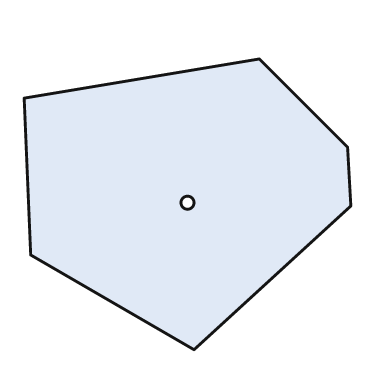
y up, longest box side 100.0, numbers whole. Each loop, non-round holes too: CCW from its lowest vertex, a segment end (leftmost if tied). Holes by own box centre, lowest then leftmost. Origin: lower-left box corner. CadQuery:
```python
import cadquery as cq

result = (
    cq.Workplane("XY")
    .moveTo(52.0, 0.0)
    .lineTo(100.0, 44.0)
    .lineTo(99.0, 62.0)
    .lineTo(72.0, 89.0)
    .lineTo(0.0, 77.0)
    .lineTo(2.0, 29.0)
    .close()
    .moveTo(50.0, 45.0)
    .circle(2.0)
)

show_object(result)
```